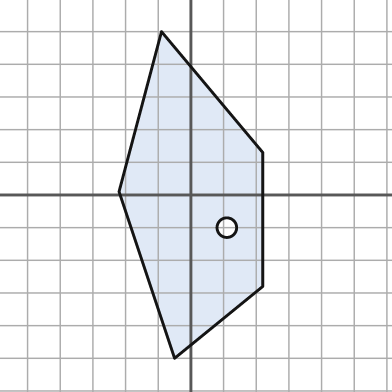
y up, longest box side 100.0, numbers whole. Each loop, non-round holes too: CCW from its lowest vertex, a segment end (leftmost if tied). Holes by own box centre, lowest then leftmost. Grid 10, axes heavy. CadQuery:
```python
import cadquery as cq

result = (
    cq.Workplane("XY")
    .moveTo(-5.0, -50.0)
    .lineTo(22.0, -28.0)
    .lineTo(22.0, 13.0)
    .lineTo(-9.0, 50.0)
    .lineTo(-22.0, 1.0)
    .close()
    .moveTo(11.0, -10.0)
    .circle(3.0)
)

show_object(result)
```